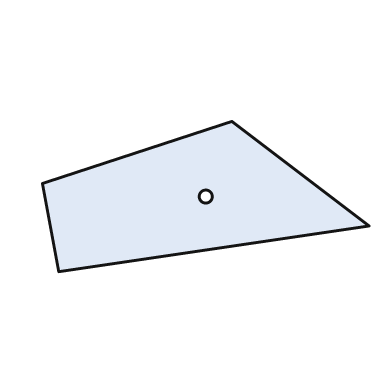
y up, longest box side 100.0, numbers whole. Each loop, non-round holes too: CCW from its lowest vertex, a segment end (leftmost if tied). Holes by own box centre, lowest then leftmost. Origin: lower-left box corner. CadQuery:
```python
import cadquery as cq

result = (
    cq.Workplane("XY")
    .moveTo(5.0, 0.0)
    .lineTo(100.0, 14.0)
    .lineTo(58.0, 46.0)
    .lineTo(0.0, 27.0)
    .close()
    .moveTo(50.0, 23.0)
    .circle(2.0)
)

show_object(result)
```